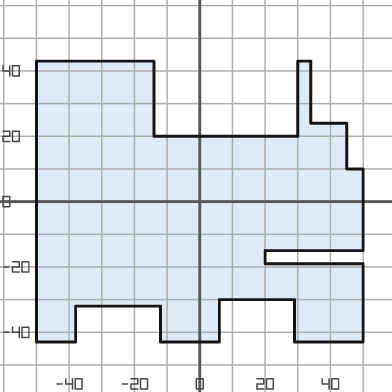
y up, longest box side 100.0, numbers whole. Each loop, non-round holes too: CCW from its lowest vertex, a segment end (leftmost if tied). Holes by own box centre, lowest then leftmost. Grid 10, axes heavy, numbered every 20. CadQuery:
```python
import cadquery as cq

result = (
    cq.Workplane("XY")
    .moveTo(-50.0, -43.0)
    .lineTo(-38.0, -43.0)
    .lineTo(-38.0, -32.0)
    .lineTo(-12.0, -32.0)
    .lineTo(-12.0, -43.0)
    .lineTo(6.0, -43.0)
    .lineTo(6.0, -30.0)
    .lineTo(29.0, -30.0)
    .lineTo(29.0, -43.0)
    .lineTo(50.0, -43.0)
    .lineTo(50.0, -19.0)
    .lineTo(20.0, -19.0)
    .lineTo(20.0, -15.0)
    .lineTo(50.0, -15.0)
    .lineTo(50.0, 10.0)
    .lineTo(45.0, 10.0)
    .lineTo(45.0, 24.0)
    .lineTo(34.0, 24.0)
    .lineTo(34.0, 43.0)
    .lineTo(30.0, 43.0)
    .lineTo(30.0, 20.0)
    .lineTo(-14.0, 20.0)
    .lineTo(-14.0, 43.0)
    .lineTo(-50.0, 43.0)
    .close()
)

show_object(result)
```